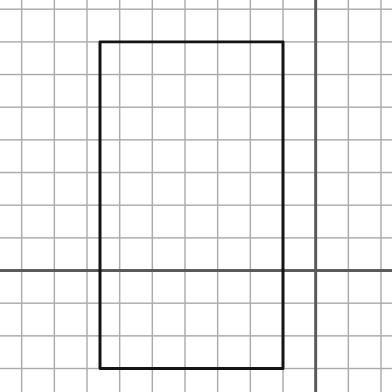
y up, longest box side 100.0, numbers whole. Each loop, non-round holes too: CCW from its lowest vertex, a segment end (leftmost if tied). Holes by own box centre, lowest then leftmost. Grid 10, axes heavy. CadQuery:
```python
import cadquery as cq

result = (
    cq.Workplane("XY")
    .moveTo(-66.0, -30.0)
    .lineTo(-10.0, -30.0)
    .lineTo(-10.0, 70.0)
    .lineTo(-66.0, 70.0)
    .close()
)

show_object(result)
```